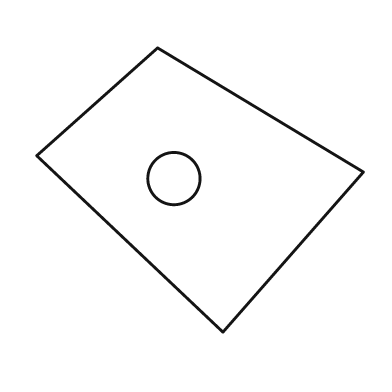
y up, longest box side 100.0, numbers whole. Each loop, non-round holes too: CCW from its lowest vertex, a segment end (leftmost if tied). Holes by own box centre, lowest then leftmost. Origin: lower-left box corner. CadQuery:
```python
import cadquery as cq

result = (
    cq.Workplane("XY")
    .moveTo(57.0, 0.0)
    .lineTo(100.0, 49.0)
    .lineTo(37.0, 87.0)
    .lineTo(0.0, 54.0)
    .close()
    .moveTo(42.0, 47.0)
    .circle(8.0)
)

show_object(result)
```